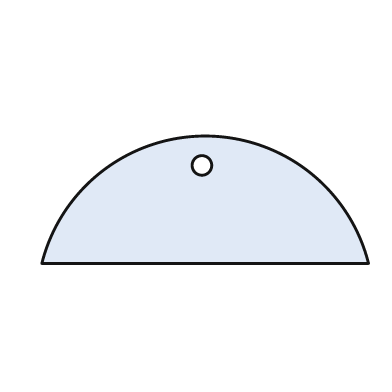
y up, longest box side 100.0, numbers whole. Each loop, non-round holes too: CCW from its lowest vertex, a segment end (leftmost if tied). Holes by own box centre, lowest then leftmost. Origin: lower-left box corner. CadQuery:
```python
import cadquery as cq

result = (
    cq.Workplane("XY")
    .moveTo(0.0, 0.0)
    .lineTo(100.0, 0.0)
    .threePointArc((50.0, 39.0), (0.0, 0.0))
    .close()
    .moveTo(49.0, 30.0)
    .circle(3.0)
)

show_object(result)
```